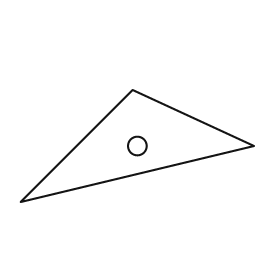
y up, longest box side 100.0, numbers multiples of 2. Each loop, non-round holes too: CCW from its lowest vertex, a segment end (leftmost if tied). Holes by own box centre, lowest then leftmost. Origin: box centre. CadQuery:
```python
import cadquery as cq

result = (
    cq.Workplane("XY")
    .moveTo(-50.0, -24.0)
    .lineTo(50.0, 0.0)
    .lineTo(-2.0, 24.0)
    .close()
    .moveTo(0.0, 0.0)
    .circle(4.0)
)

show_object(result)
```